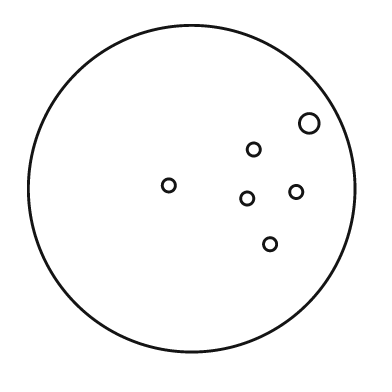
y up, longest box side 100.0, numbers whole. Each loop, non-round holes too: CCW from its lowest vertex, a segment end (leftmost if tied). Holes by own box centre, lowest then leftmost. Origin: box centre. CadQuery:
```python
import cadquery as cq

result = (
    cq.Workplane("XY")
    .moveTo(0.0, 0.0)
    .circle(50.0)
    .moveTo(24.0, -17.0)
    .circle(2.0)
    .moveTo(17.0, -3.0)
    .circle(2.0)
    .moveTo(32.0, -1.0)
    .circle(2.0)
    .moveTo(-7.0, 1.0)
    .circle(2.0)
    .moveTo(19.0, 12.0)
    .circle(2.0)
    .moveTo(36.0, 20.0)
    .circle(3.0)
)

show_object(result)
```